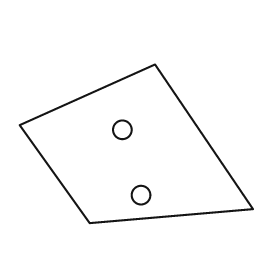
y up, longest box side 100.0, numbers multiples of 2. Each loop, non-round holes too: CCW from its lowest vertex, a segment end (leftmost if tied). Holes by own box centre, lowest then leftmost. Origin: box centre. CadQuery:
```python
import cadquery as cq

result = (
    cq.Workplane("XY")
    .moveTo(-20.0, -34.0)
    .lineTo(50.0, -28.0)
    .lineTo(8.0, 34.0)
    .lineTo(-50.0, 8.0)
    .close()
    .moveTo(2.0, -22.0)
    .circle(4.0)
    .moveTo(-6.0, 6.0)
    .circle(4.0)
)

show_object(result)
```